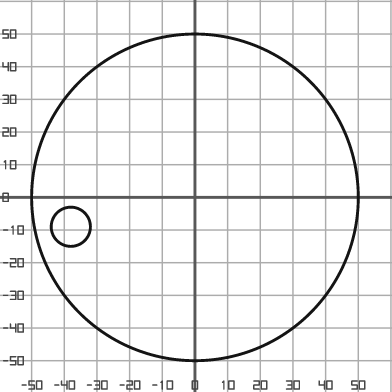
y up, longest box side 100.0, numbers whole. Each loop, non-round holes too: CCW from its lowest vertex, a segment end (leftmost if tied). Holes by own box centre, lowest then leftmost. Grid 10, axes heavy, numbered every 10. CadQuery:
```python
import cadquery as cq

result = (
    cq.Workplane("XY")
    .moveTo(0.0, 0.0)
    .circle(50.0)
    .moveTo(-38.0, -9.0)
    .circle(6.0)
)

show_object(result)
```